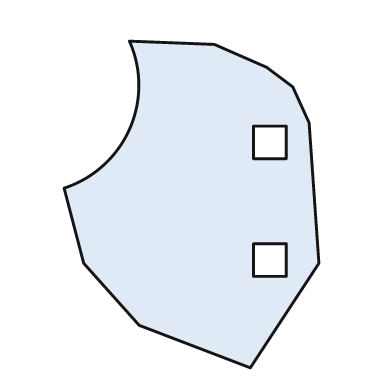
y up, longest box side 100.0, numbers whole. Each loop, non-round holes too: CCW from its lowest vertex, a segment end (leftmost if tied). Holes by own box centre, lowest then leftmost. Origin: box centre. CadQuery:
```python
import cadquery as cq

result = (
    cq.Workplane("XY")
    .moveTo(18.0, -50.0)
    .lineTo(39.0, -18.0)
    .lineTo(36.0, 25.0)
    .lineTo(31.0, 36.0)
    .lineTo(23.0, 42.0)
    .lineTo(7.0, 49.0)
    .lineTo(-19.0, 50.0)
    .threePointArc((-19.0, 23.0), (-39.0, 5.0))
    .lineTo(-33.0, -18.0)
    .lineTo(-16.0, -37.0)
    .close()
    .moveTo(19.0, -22.0)
    .lineTo(29.0, -22.0)
    .lineTo(29.0, -12.0)
    .lineTo(19.0, -12.0)
    .close()
    .moveTo(19.0, 14.0)
    .lineTo(29.0, 14.0)
    .lineTo(29.0, 24.0)
    .lineTo(19.0, 24.0)
    .close()
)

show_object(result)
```